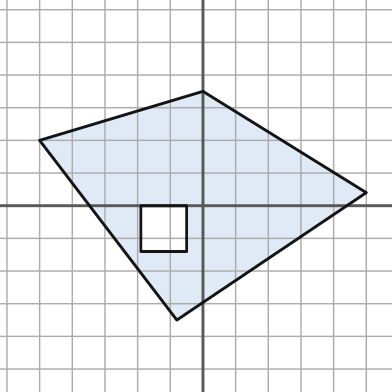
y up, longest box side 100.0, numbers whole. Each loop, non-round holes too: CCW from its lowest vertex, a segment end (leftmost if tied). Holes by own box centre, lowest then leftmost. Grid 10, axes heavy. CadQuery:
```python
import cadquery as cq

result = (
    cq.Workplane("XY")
    .moveTo(-8.0, -35.0)
    .lineTo(50.0, 4.0)
    .lineTo(0.0, 35.0)
    .lineTo(-50.0, 20.0)
    .close()
    .moveTo(-19.0, -14.0)
    .lineTo(-5.0, -14.0)
    .lineTo(-5.0, 0.0)
    .lineTo(-19.0, 0.0)
    .close()
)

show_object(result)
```